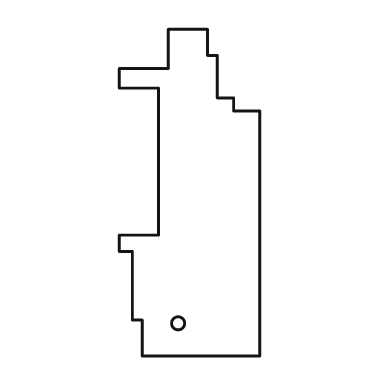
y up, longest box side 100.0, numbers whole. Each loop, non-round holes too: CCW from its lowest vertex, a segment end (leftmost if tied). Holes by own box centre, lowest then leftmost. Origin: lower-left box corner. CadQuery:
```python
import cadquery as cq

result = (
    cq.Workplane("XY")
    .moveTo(7.0, 0.0)
    .lineTo(43.0, 0.0)
    .lineTo(43.0, 75.0)
    .lineTo(35.0, 75.0)
    .lineTo(35.0, 79.0)
    .lineTo(30.0, 79.0)
    .lineTo(30.0, 92.0)
    .lineTo(27.0, 92.0)
    .lineTo(27.0, 100.0)
    .lineTo(15.0, 100.0)
    .lineTo(15.0, 88.0)
    .lineTo(0.0, 88.0)
    .lineTo(0.0, 82.0)
    .lineTo(12.0, 82.0)
    .lineTo(12.0, 37.0)
    .lineTo(0.0, 37.0)
    .lineTo(0.0, 32.0)
    .lineTo(4.0, 32.0)
    .lineTo(4.0, 11.0)
    .lineTo(7.0, 11.0)
    .close()
    .moveTo(18.0, 10.0)
    .circle(2.0)
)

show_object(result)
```